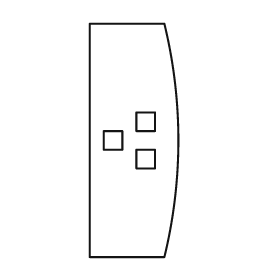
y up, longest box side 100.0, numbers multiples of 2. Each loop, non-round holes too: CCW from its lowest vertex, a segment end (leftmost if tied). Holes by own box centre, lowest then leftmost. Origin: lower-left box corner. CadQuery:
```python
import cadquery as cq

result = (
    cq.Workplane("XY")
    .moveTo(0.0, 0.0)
    .lineTo(32.0, 0.0)
    .threePointArc((38.0, 50.0), (32.0, 100.0))
    .lineTo(0.0, 100.0)
    .close()
    .moveTo(20.0, 38.0)
    .lineTo(28.0, 38.0)
    .lineTo(28.0, 46.0)
    .lineTo(20.0, 46.0)
    .close()
    .moveTo(6.0, 46.0)
    .lineTo(14.0, 46.0)
    .lineTo(14.0, 54.0)
    .lineTo(6.0, 54.0)
    .close()
    .moveTo(20.0, 54.0)
    .lineTo(28.0, 54.0)
    .lineTo(28.0, 62.0)
    .lineTo(20.0, 62.0)
    .close()
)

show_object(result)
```